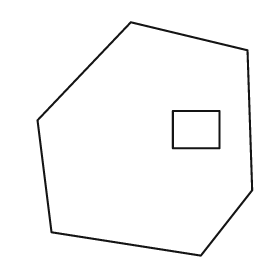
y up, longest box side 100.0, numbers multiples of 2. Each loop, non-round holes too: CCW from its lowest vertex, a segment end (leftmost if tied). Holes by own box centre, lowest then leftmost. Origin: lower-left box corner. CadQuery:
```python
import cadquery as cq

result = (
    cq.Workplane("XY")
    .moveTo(70.0, 0.0)
    .lineTo(92.0, 28.0)
    .lineTo(90.0, 88.0)
    .lineTo(40.0, 100.0)
    .lineTo(0.0, 58.0)
    .lineTo(6.0, 10.0)
    .close()
    .moveTo(58.0, 46.0)
    .lineTo(78.0, 46.0)
    .lineTo(78.0, 62.0)
    .lineTo(58.0, 62.0)
    .close()
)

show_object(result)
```